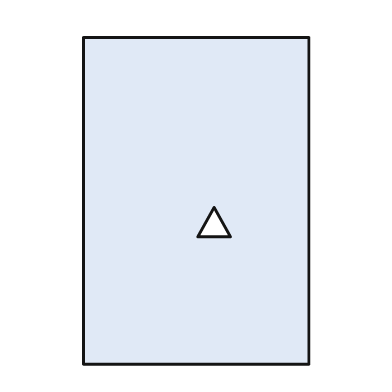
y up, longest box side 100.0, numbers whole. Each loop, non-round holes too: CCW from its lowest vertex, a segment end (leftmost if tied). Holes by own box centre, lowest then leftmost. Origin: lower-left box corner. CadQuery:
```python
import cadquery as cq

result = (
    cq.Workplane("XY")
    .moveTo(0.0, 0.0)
    .lineTo(69.0, 0.0)
    .lineTo(69.0, 100.0)
    .lineTo(0.0, 100.0)
    .close()
    .moveTo(35.0, 39.0)
    .lineTo(45.0, 39.0)
    .lineTo(40.0, 48.0)
    .close()
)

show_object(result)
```